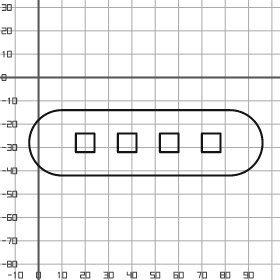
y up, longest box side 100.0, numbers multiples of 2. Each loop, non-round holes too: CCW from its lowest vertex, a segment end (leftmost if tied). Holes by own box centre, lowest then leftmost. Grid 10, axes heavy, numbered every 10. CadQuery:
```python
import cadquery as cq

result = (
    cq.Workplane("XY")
    .moveTo(10.0, -42.0)
    .lineTo(82.0, -42.0)
    .threePointArc((96.0, -28.0), (82.0, -14.0))
    .lineTo(10.0, -14.0)
    .threePointArc((-4.0, -28.0), (10.0, -42.0))
    .close()
    .moveTo(16.0, -32.0)
    .lineTo(24.0, -32.0)
    .lineTo(24.0, -24.0)
    .lineTo(16.0, -24.0)
    .close()
    .moveTo(34.0, -32.0)
    .lineTo(42.0, -32.0)
    .lineTo(42.0, -24.0)
    .lineTo(34.0, -24.0)
    .close()
    .moveTo(52.0, -32.0)
    .lineTo(60.0, -32.0)
    .lineTo(60.0, -24.0)
    .lineTo(52.0, -24.0)
    .close()
    .moveTo(70.0, -32.0)
    .lineTo(78.0, -32.0)
    .lineTo(78.0, -24.0)
    .lineTo(70.0, -24.0)
    .close()
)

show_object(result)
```